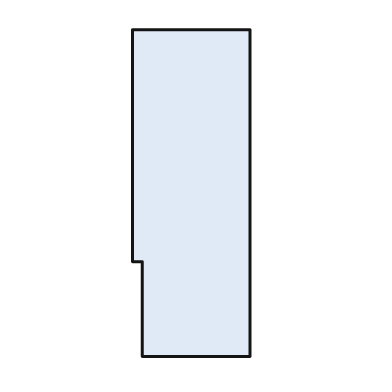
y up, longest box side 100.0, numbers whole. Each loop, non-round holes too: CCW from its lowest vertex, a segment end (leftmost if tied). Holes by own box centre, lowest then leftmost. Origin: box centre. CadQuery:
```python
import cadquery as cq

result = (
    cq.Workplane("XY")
    .moveTo(-15.0, -50.0)
    .lineTo(18.0, -50.0)
    .lineTo(18.0, 50.0)
    .lineTo(-18.0, 50.0)
    .lineTo(-18.0, -21.0)
    .lineTo(-15.0, -21.0)
    .close()
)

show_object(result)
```